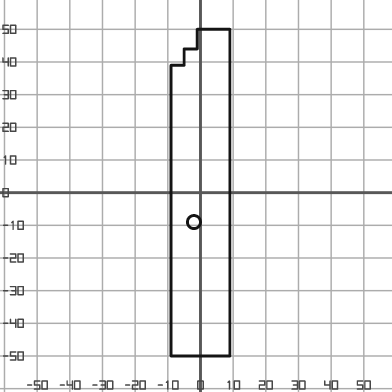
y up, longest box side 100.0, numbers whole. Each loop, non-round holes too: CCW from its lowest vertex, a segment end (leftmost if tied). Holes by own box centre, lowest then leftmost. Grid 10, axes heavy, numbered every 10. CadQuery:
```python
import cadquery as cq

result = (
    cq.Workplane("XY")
    .moveTo(-9.0, -50.0)
    .lineTo(9.0, -50.0)
    .lineTo(9.0, 50.0)
    .lineTo(-1.0, 50.0)
    .lineTo(-1.0, 44.0)
    .lineTo(-5.0, 44.0)
    .lineTo(-5.0, 39.0)
    .lineTo(-9.0, 39.0)
    .close()
    .moveTo(-2.0, -9.0)
    .circle(2.0)
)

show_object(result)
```